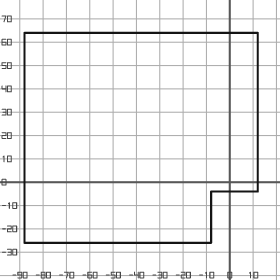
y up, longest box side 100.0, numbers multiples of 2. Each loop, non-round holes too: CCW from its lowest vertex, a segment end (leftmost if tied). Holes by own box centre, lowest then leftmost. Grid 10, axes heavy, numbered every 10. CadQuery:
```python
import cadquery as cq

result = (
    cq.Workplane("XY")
    .moveTo(-88.0, -26.0)
    .lineTo(-8.0, -26.0)
    .lineTo(-8.0, -4.0)
    .lineTo(12.0, -4.0)
    .lineTo(12.0, 64.0)
    .lineTo(-88.0, 64.0)
    .close()
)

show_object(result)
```